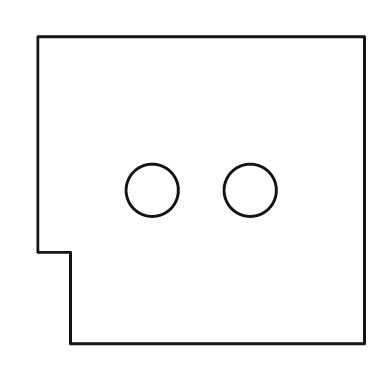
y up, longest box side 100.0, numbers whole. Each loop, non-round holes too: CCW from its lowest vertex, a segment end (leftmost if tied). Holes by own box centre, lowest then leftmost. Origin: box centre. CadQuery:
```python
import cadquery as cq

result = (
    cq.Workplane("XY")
    .moveTo(-40.0, -47.0)
    .lineTo(50.0, -47.0)
    .lineTo(50.0, 47.0)
    .lineTo(-50.0, 47.0)
    .lineTo(-50.0, -19.0)
    .lineTo(-40.0, -19.0)
    .close()
    .moveTo(-15.0, 0.0)
    .circle(8.0)
    .moveTo(15.0, 0.0)
    .circle(8.0)
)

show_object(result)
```